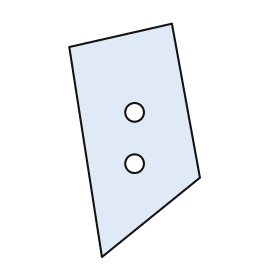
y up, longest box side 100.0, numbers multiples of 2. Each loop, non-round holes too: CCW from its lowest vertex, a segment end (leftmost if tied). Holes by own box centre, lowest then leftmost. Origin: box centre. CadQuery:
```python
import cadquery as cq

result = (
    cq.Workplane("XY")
    .moveTo(-14.0, -50.0)
    .lineTo(28.0, -16.0)
    .lineTo(16.0, 50.0)
    .lineTo(-28.0, 40.0)
    .close()
    .moveTo(0.0, -10.0)
    .circle(4.0)
    .moveTo(0.0, 12.0)
    .circle(4.0)
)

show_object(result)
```